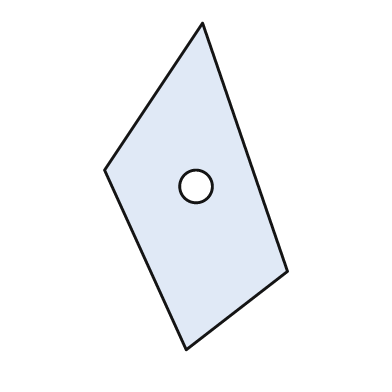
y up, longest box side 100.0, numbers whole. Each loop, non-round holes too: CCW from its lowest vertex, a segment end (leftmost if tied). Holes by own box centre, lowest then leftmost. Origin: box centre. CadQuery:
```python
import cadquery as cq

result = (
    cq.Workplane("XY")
    .moveTo(-3.0, -50.0)
    .lineTo(28.0, -26.0)
    .lineTo(2.0, 50.0)
    .lineTo(-28.0, 5.0)
    .close()
    .moveTo(0.0, 0.0)
    .circle(5.0)
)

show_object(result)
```